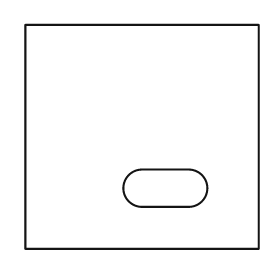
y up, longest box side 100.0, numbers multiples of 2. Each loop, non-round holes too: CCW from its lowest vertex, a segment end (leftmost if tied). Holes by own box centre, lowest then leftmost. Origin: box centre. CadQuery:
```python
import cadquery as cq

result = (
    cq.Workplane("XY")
    .moveTo(-50.0, -48.0)
    .lineTo(50.0, -48.0)
    .lineTo(50.0, 48.0)
    .lineTo(-50.0, 48.0)
    .close()
    .moveTo(0.0, -30.0)
    .lineTo(20.0, -30.0)
    .threePointArc((28.0, -22.0), (20.0, -14.0))
    .lineTo(0.0, -14.0)
    .threePointArc((-8.0, -22.0), (0.0, -30.0))
    .close()
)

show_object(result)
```